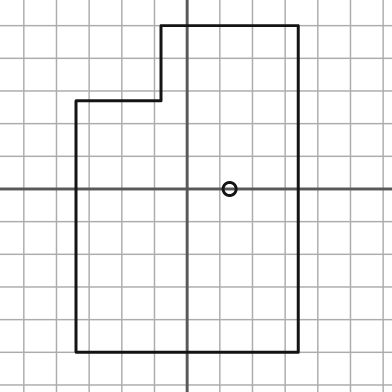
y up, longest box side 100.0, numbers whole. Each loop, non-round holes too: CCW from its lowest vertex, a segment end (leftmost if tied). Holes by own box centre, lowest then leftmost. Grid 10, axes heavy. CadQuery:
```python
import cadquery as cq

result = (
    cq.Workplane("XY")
    .moveTo(-34.0, -50.0)
    .lineTo(34.0, -50.0)
    .lineTo(34.0, 50.0)
    .lineTo(-8.0, 50.0)
    .lineTo(-8.0, 27.0)
    .lineTo(-34.0, 27.0)
    .close()
    .moveTo(13.0, 0.0)
    .circle(2.0)
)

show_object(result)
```